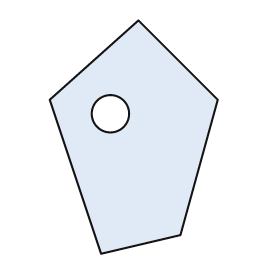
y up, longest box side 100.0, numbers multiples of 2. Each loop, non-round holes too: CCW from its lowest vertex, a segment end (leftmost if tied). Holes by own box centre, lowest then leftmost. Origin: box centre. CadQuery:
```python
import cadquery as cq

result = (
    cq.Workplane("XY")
    .moveTo(-14.0, -50.0)
    .lineTo(20.0, -42.0)
    .lineTo(36.0, 16.0)
    .lineTo(2.0, 50.0)
    .lineTo(-36.0, 16.0)
    .close()
    .moveTo(-10.0, 10.0)
    .circle(8.0)
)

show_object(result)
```